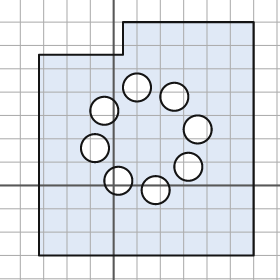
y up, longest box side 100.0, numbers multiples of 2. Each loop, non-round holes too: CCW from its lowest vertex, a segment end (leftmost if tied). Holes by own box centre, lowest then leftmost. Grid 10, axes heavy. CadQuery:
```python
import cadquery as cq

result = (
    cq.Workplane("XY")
    .moveTo(-32.0, -30.0)
    .lineTo(60.0, -30.0)
    .lineTo(60.0, 70.0)
    .lineTo(4.0, 70.0)
    .lineTo(4.0, 56.0)
    .lineTo(-32.0, 56.0)
    .close()
    .moveTo(18.0, -2.0)
    .circle(6.0)
    .moveTo(2.0, 2.0)
    .circle(6.0)
    .moveTo(32.0, 8.0)
    .circle(6.0)
    .moveTo(-8.0, 16.0)
    .circle(6.0)
    .moveTo(36.0, 24.0)
    .circle(6.0)
    .moveTo(-4.0, 32.0)
    .circle(6.0)
    .moveTo(26.0, 38.0)
    .circle(6.0)
    .moveTo(10.0, 42.0)
    .circle(6.0)
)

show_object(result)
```